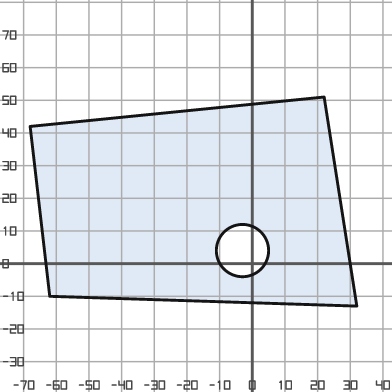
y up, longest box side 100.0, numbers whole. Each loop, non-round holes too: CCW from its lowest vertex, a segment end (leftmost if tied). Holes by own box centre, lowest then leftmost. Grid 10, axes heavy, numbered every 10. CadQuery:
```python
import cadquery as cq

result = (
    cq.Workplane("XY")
    .moveTo(32.0, -13.0)
    .lineTo(22.0, 51.0)
    .lineTo(-68.0, 42.0)
    .lineTo(-62.0, -10.0)
    .close()
    .moveTo(-3.0, 4.0)
    .circle(8.0)
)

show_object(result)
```